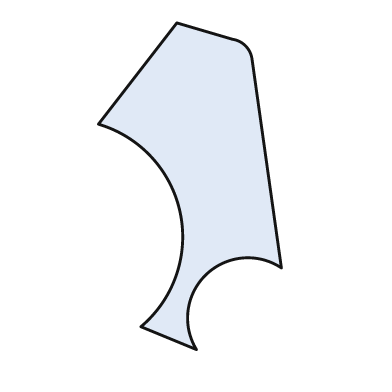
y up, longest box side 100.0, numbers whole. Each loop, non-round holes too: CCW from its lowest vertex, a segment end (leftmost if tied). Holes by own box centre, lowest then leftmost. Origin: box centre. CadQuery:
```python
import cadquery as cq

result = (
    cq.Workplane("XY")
    .moveTo(2.0, -50.0)
    .threePointArc((5.0, -27.0), (28.0, -25.0))
    .lineTo(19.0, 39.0)
    .threePointArc((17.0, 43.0), (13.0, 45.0))
    .lineTo(-4.0, 50.0)
    .lineTo(-28.0, 19.0)
    .threePointArc((-3.0, -8.0), (-15.0, -43.0))
    .close()
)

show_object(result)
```